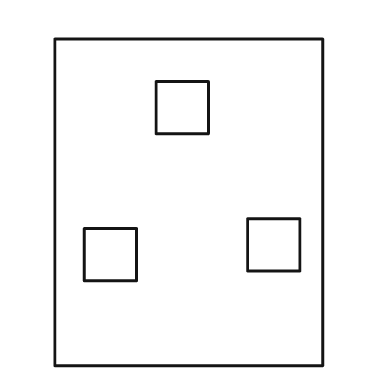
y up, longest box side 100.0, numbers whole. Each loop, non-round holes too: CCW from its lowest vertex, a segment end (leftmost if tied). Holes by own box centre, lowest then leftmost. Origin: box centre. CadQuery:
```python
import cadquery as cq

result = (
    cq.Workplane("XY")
    .moveTo(-41.0, -50.0)
    .lineTo(41.0, -50.0)
    .lineTo(41.0, 50.0)
    .lineTo(-41.0, 50.0)
    .close()
    .moveTo(-32.0, -24.0)
    .lineTo(-16.0, -24.0)
    .lineTo(-16.0, -8.0)
    .lineTo(-32.0, -8.0)
    .close()
    .moveTo(18.0, -21.0)
    .lineTo(34.0, -21.0)
    .lineTo(34.0, -5.0)
    .lineTo(18.0, -5.0)
    .close()
    .moveTo(-10.0, 21.0)
    .lineTo(6.0, 21.0)
    .lineTo(6.0, 37.0)
    .lineTo(-10.0, 37.0)
    .close()
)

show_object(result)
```